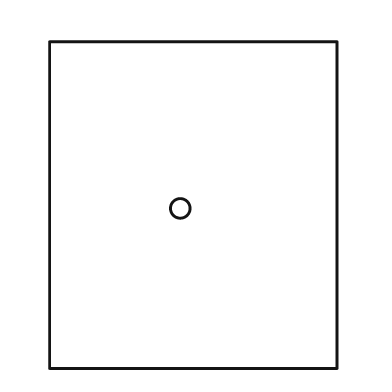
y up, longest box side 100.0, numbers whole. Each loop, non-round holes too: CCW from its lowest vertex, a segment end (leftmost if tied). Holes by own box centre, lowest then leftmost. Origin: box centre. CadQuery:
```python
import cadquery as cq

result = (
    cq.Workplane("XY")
    .moveTo(-44.0, -50.0)
    .lineTo(44.0, -50.0)
    .lineTo(44.0, 50.0)
    .lineTo(-44.0, 50.0)
    .close()
    .moveTo(-4.0, -1.0)
    .circle(3.0)
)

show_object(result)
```